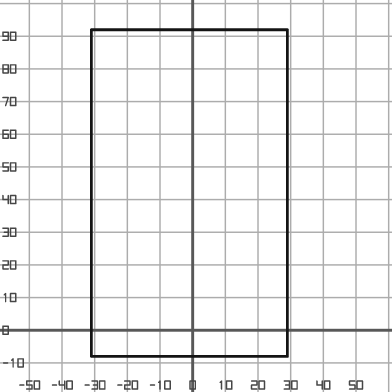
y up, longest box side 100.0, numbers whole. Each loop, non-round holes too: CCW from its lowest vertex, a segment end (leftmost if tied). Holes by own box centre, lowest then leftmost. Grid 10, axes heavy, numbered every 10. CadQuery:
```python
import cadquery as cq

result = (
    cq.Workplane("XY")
    .moveTo(-31.0, -8.0)
    .lineTo(29.0, -8.0)
    .lineTo(29.0, 92.0)
    .lineTo(-31.0, 92.0)
    .close()
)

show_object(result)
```